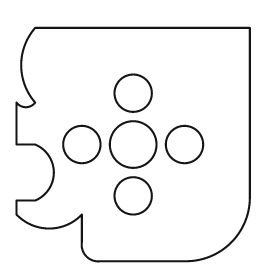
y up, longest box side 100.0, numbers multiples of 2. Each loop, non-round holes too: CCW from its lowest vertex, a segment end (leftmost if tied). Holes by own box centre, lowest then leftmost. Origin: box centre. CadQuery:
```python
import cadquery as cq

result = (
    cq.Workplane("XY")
    .moveTo(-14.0, -50.0)
    .lineTo(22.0, -50.0)
    .threePointArc((42.0, -42.0), (50.0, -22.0))
    .lineTo(50.0, 50.0)
    .lineTo(-42.0, 50.0)
    .threePointArc((-48.0, 34.0), (-42.0, 18.0))
    .threePointArc((-46.0, 16.0), (-50.0, 18.0))
    .lineTo(-50.0, 0.0)
    .lineTo(-42.0, 0.0)
    .threePointArc((-34.0, -12.0), (-42.0, -24.0))
    .lineTo(-50.0, -24.0)
    .lineTo(-50.0, -30.0)
    .threePointArc((-36.0, -36.0), (-22.0, -30.0))
    .lineTo(-22.0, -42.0)
    .threePointArc((-20.0, -48.0), (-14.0, -50.0))
    .close()
    .moveTo(0.0, -22.0)
    .circle(8.0)
    .moveTo(-22.0, 0.0)
    .circle(8.0)
    .moveTo(0.0, 0.0)
    .circle(10.0)
    .moveTo(22.0, 0.0)
    .circle(8.0)
    .moveTo(0.0, 22.0)
    .circle(8.0)
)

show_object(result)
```